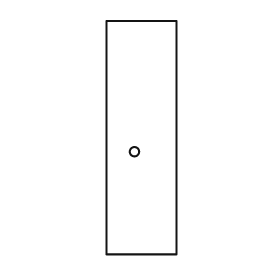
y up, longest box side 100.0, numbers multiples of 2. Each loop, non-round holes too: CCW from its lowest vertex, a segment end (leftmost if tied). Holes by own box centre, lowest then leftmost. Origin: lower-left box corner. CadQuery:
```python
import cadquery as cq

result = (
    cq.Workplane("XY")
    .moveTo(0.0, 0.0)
    .lineTo(30.0, 0.0)
    .lineTo(30.0, 100.0)
    .lineTo(0.0, 100.0)
    .close()
    .moveTo(12.0, 44.0)
    .circle(2.0)
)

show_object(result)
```